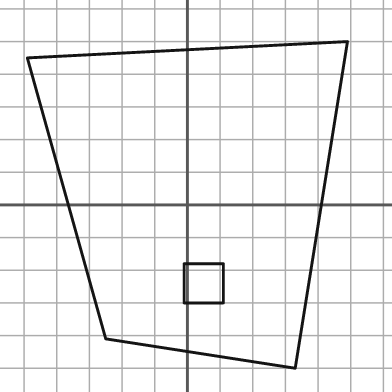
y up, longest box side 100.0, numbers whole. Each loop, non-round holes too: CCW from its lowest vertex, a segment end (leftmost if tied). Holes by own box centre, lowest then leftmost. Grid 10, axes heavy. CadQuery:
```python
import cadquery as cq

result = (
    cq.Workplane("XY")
    .moveTo(33.0, -50.0)
    .lineTo(49.0, 50.0)
    .lineTo(-49.0, 45.0)
    .lineTo(-25.0, -41.0)
    .close()
    .moveTo(-1.0, -30.0)
    .lineTo(11.0, -30.0)
    .lineTo(11.0, -18.0)
    .lineTo(-1.0, -18.0)
    .close()
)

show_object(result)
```